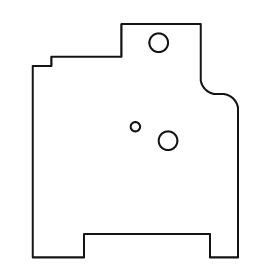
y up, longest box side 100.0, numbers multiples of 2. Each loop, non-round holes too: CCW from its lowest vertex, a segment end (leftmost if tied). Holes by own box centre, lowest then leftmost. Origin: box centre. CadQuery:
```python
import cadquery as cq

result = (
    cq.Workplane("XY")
    .moveTo(-44.0, -50.0)
    .lineTo(-22.0, -50.0)
    .lineTo(-22.0, -40.0)
    .lineTo(32.0, -40.0)
    .lineTo(32.0, -50.0)
    .lineTo(44.0, -50.0)
    .lineTo(44.0, 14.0)
    .threePointArc((42.0, 18.0), (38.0, 20.0))
    .lineTo(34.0, 20.0)
    .threePointArc((30.0, 22.0), (28.0, 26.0))
    .lineTo(28.0, 50.0)
    .lineTo(-6.0, 50.0)
    .lineTo(-6.0, 36.0)
    .lineTo(-36.0, 36.0)
    .lineTo(-36.0, 32.0)
    .lineTo(-44.0, 32.0)
    .close()
    .moveTo(14.0, 0.0)
    .circle(4.0)
    .moveTo(0.0, 6.0)
    .circle(2.0)
    .moveTo(10.0, 42.0)
    .circle(4.0)
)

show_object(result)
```